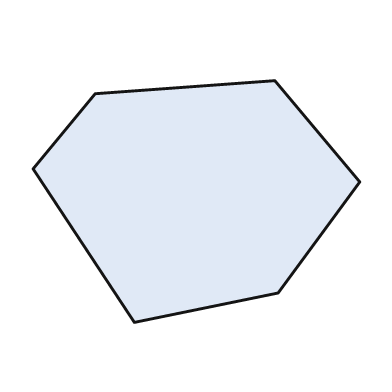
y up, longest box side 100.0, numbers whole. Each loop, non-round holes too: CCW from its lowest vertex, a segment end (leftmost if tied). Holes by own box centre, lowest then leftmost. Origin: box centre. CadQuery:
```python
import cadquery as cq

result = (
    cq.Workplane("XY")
    .moveTo(-19.0, -37.0)
    .lineTo(25.0, -28.0)
    .lineTo(50.0, 6.0)
    .lineTo(24.0, 37.0)
    .lineTo(-31.0, 33.0)
    .lineTo(-50.0, 10.0)
    .close()
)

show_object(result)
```